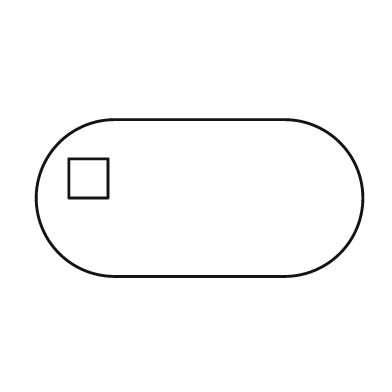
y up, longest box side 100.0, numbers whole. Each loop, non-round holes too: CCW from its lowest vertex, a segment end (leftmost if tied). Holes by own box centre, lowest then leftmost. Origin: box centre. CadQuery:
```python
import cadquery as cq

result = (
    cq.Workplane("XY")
    .moveTo(-26.0, -24.0)
    .lineTo(26.0, -24.0)
    .threePointArc((50.0, 0.0), (26.0, 24.0))
    .lineTo(-26.0, 24.0)
    .threePointArc((-50.0, 0.0), (-26.0, -24.0))
    .close()
    .moveTo(-40.0, 0.0)
    .lineTo(-28.0, 0.0)
    .lineTo(-28.0, 12.0)
    .lineTo(-40.0, 12.0)
    .close()
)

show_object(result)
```